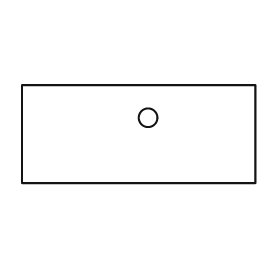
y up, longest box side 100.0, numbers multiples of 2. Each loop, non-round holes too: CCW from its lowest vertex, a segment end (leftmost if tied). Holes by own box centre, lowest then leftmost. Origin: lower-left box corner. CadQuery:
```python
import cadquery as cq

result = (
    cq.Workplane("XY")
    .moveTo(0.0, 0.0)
    .lineTo(100.0, 0.0)
    .lineTo(100.0, 42.0)
    .lineTo(0.0, 42.0)
    .close()
    .moveTo(54.0, 28.0)
    .circle(4.0)
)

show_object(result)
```